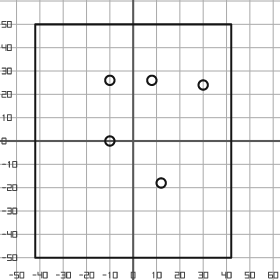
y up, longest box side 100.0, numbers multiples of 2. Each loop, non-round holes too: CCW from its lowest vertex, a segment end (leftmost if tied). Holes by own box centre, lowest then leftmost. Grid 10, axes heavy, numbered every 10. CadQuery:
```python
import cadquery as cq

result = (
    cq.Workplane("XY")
    .moveTo(-42.0, -50.0)
    .lineTo(42.0, -50.0)
    .lineTo(42.0, 50.0)
    .lineTo(-42.0, 50.0)
    .close()
    .moveTo(12.0, -18.0)
    .circle(2.0)
    .moveTo(-10.0, 0.0)
    .circle(2.0)
    .moveTo(30.0, 24.0)
    .circle(2.0)
    .moveTo(-10.0, 26.0)
    .circle(2.0)
    .moveTo(8.0, 26.0)
    .circle(2.0)
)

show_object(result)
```